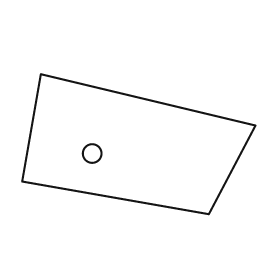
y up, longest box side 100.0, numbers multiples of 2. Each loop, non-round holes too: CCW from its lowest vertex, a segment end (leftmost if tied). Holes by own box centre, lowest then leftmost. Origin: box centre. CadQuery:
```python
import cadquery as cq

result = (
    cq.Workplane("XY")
    .moveTo(30.0, -30.0)
    .lineTo(50.0, 8.0)
    .lineTo(-42.0, 30.0)
    .lineTo(-50.0, -16.0)
    .close()
    .moveTo(-20.0, -4.0)
    .circle(4.0)
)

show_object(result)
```